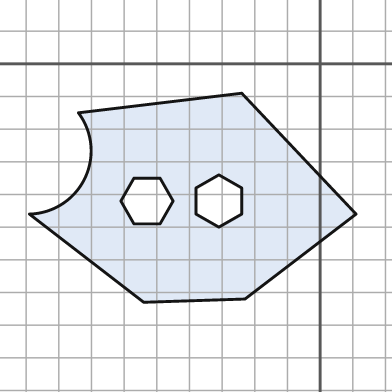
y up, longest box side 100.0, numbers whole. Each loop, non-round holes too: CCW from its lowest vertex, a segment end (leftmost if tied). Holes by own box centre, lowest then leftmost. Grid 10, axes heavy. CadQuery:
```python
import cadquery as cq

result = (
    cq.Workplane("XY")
    .moveTo(-54.0, -73.0)
    .lineTo(-23.0, -72.0)
    .lineTo(11.0, -46.0)
    .lineTo(-24.0, -9.0)
    .lineTo(-74.0, -15.0)
    .threePointArc((-72.0, -35.0), (-89.0, -46.0))
    .close()
    .moveTo(-57.0, -49.0)
    .lineTo(-49.0, -49.0)
    .lineTo(-45.0, -42.0)
    .lineTo(-49.0, -35.0)
    .lineTo(-57.0, -35.0)
    .lineTo(-61.0, -42.0)
    .close()
    .moveTo(-31.0, -50.0)
    .lineTo(-24.0, -46.0)
    .lineTo(-24.0, -38.0)
    .lineTo(-31.0, -34.0)
    .lineTo(-38.0, -38.0)
    .lineTo(-38.0, -46.0)
    .close()
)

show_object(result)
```